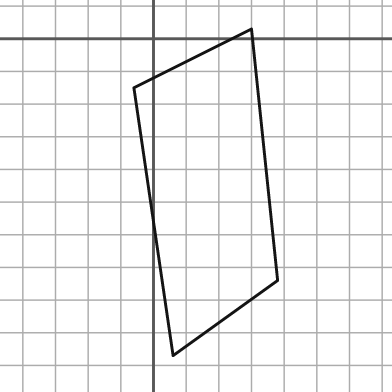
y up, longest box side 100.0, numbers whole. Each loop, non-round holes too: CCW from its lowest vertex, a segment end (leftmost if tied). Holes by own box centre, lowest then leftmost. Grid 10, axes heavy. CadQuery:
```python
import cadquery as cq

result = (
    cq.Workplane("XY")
    .moveTo(6.0, -97.0)
    .lineTo(38.0, -74.0)
    .lineTo(30.0, 3.0)
    .lineTo(-6.0, -15.0)
    .close()
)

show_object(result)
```